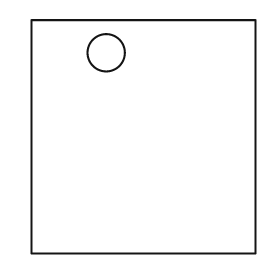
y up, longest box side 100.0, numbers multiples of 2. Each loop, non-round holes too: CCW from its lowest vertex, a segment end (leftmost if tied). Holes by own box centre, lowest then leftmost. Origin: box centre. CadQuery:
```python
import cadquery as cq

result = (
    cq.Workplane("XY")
    .moveTo(-48.0, -50.0)
    .lineTo(48.0, -50.0)
    .lineTo(48.0, 50.0)
    .lineTo(-48.0, 50.0)
    .close()
    .moveTo(-16.0, 36.0)
    .circle(8.0)
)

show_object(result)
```